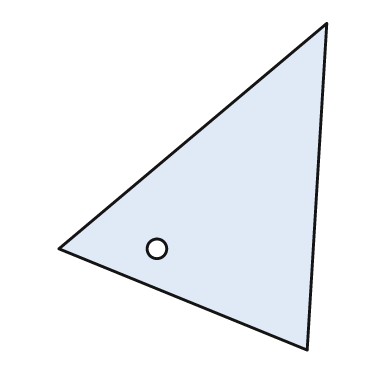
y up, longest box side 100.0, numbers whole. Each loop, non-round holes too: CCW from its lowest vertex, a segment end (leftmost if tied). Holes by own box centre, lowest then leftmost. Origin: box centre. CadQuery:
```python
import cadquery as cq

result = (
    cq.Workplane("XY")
    .moveTo(35.0, -50.0)
    .lineTo(41.0, 50.0)
    .lineTo(-41.0, -19.0)
    .close()
    .moveTo(-11.0, -19.0)
    .circle(3.0)
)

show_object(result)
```